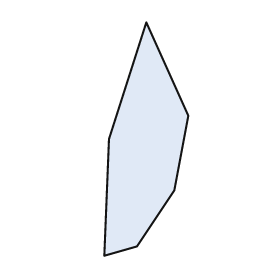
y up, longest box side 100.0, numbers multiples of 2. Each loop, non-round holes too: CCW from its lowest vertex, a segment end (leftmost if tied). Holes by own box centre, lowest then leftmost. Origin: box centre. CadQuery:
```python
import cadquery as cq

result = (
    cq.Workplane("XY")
    .moveTo(-18.0, -50.0)
    .lineTo(-4.0, -46.0)
    .lineTo(12.0, -22.0)
    .lineTo(18.0, 10.0)
    .lineTo(0.0, 50.0)
    .lineTo(-16.0, 0.0)
    .close()
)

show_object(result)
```